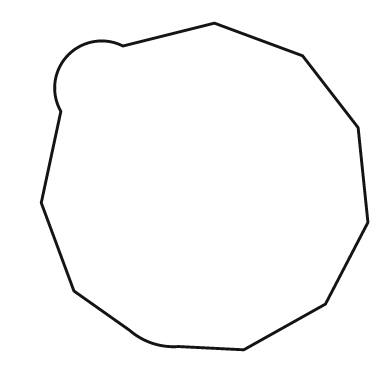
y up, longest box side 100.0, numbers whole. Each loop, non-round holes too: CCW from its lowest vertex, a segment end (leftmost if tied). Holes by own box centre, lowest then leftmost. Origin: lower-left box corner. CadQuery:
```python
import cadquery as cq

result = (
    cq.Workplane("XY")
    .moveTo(62.0, 0.0)
    .lineTo(87.0, 14.0)
    .lineTo(100.0, 39.0)
    .lineTo(97.0, 68.0)
    .lineTo(80.0, 90.0)
    .lineTo(53.0, 100.0)
    .lineTo(25.0, 93.0)
    .threePointArc((8.0, 90.0), (6.0, 73.0))
    .lineTo(0.0, 45.0)
    .lineTo(10.0, 18.0)
    .lineTo(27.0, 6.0)
    .threePointArc((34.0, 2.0), (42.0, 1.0))
    .close()
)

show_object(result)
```